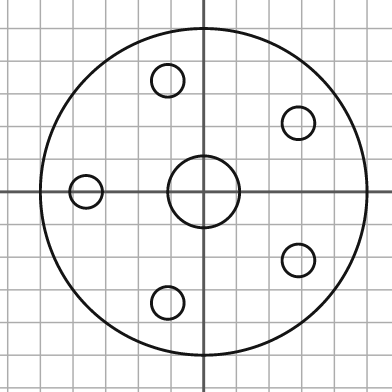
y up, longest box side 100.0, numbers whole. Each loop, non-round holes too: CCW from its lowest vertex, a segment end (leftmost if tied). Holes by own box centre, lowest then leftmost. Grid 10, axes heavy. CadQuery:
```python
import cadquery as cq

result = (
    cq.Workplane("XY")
    .moveTo(0.0, 0.0)
    .circle(50.0)
    .moveTo(-11.0, -34.0)
    .circle(5.0)
    .moveTo(29.0, -21.0)
    .circle(5.0)
    .moveTo(-36.0, 0.0)
    .circle(5.0)
    .moveTo(0.0, 0.0)
    .circle(11.0)
    .moveTo(29.0, 21.0)
    .circle(5.0)
    .moveTo(-11.0, 34.0)
    .circle(5.0)
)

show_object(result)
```